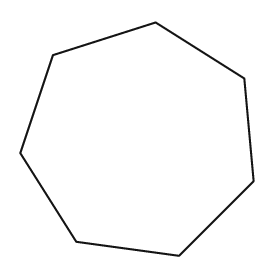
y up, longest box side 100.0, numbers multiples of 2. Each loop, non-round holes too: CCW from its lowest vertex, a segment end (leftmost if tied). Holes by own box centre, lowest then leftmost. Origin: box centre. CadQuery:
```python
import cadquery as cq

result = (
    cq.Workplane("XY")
    .moveTo(18.0, -50.0)
    .lineTo(50.0, -18.0)
    .lineTo(46.0, 26.0)
    .lineTo(8.0, 50.0)
    .lineTo(-36.0, 36.0)
    .lineTo(-50.0, -6.0)
    .lineTo(-26.0, -44.0)
    .close()
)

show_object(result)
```